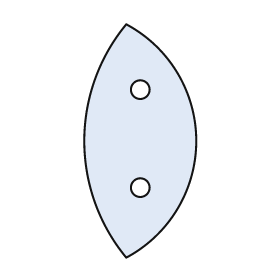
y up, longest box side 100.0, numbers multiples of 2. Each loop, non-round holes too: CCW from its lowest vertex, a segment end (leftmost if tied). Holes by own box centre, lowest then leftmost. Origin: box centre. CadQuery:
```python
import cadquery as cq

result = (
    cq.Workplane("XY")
    .moveTo(-6.0, -50.0)
    .threePointArc((24.0, 0.0), (-6.0, 50.0))
    .threePointArc((-24.0, 0.0), (-6.0, -50.0))
    .close()
    .moveTo(0.0, -20.0)
    .circle(4.0)
    .moveTo(0.0, 22.0)
    .circle(4.0)
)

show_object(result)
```